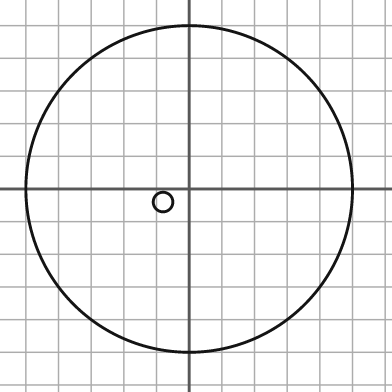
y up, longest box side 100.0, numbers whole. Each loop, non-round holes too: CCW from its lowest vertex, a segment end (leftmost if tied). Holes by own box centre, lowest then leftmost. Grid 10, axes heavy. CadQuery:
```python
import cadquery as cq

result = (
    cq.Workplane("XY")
    .moveTo(0.0, 0.0)
    .circle(50.0)
    .moveTo(-8.0, -4.0)
    .circle(3.0)
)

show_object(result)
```